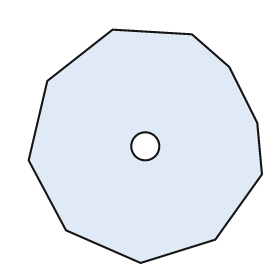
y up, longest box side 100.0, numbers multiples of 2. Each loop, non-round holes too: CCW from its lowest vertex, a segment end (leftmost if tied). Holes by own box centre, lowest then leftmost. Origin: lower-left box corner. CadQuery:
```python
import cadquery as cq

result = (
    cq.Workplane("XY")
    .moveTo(48.0, 0.0)
    .lineTo(80.0, 10.0)
    .lineTo(100.0, 38.0)
    .lineTo(98.0, 60.0)
    .lineTo(86.0, 84.0)
    .lineTo(70.0, 98.0)
    .lineTo(36.0, 100.0)
    .lineTo(8.0, 78.0)
    .lineTo(0.0, 44.0)
    .lineTo(16.0, 14.0)
    .close()
    .moveTo(50.0, 50.0)
    .circle(6.0)
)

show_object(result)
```